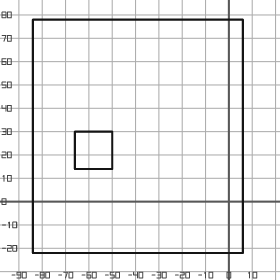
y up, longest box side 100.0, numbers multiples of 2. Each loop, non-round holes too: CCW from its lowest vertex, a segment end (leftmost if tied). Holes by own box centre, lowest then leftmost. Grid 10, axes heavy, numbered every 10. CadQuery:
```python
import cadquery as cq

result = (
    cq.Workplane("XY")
    .moveTo(-84.0, -22.0)
    .lineTo(6.0, -22.0)
    .lineTo(6.0, 78.0)
    .lineTo(-84.0, 78.0)
    .close()
    .moveTo(-66.0, 14.0)
    .lineTo(-50.0, 14.0)
    .lineTo(-50.0, 30.0)
    .lineTo(-66.0, 30.0)
    .close()
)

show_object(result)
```